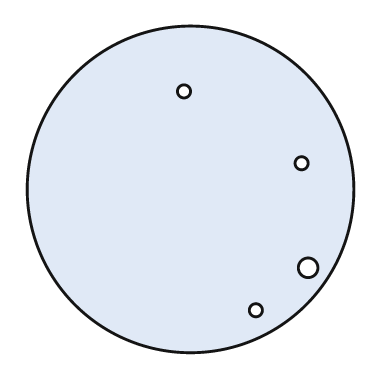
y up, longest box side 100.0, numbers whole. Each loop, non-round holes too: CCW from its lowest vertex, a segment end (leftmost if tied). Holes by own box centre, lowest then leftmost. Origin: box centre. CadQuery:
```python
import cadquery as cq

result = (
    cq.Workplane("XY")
    .moveTo(0.0, 0.0)
    .circle(50.0)
    .moveTo(20.0, -37.0)
    .circle(2.0)
    .moveTo(36.0, -24.0)
    .circle(3.0)
    .moveTo(34.0, 8.0)
    .circle(2.0)
    .moveTo(-2.0, 30.0)
    .circle(2.0)
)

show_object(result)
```